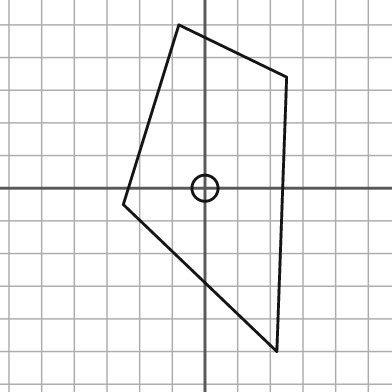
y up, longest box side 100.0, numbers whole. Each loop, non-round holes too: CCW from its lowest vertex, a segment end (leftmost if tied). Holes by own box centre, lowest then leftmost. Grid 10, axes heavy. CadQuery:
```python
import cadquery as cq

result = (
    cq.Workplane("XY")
    .moveTo(22.0, -50.0)
    .lineTo(25.0, 34.0)
    .lineTo(-8.0, 50.0)
    .lineTo(-25.0, -5.0)
    .close()
    .moveTo(0.0, 0.0)
    .circle(4.0)
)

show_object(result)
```